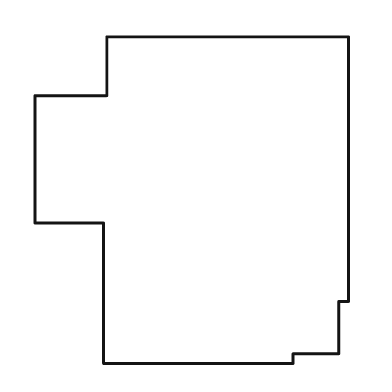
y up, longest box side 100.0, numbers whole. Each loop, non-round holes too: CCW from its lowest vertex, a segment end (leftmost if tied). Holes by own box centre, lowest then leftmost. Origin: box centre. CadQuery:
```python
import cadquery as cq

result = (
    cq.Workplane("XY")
    .moveTo(-27.0, -50.0)
    .lineTo(31.0, -50.0)
    .lineTo(31.0, -47.0)
    .lineTo(45.0, -47.0)
    .lineTo(45.0, -31.0)
    .lineTo(48.0, -31.0)
    .lineTo(48.0, 50.0)
    .lineTo(-26.0, 50.0)
    .lineTo(-26.0, 32.0)
    .lineTo(-48.0, 32.0)
    .lineTo(-48.0, -7.0)
    .lineTo(-27.0, -7.0)
    .close()
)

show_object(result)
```